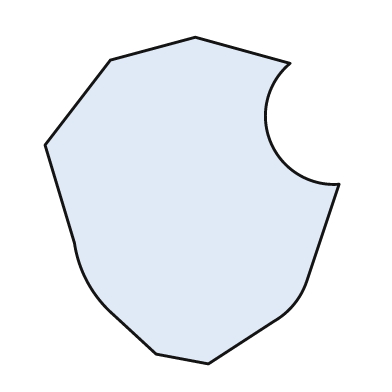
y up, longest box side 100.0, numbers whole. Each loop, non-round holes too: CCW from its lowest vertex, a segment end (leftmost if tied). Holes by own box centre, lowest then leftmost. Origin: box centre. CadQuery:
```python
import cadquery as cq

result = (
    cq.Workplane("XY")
    .moveTo(5.0, -50.0)
    .lineTo(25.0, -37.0)
    .threePointArc((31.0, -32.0), (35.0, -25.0))
    .lineTo(45.0, 5.0)
    .threePointArc((24.0, 18.0), (30.0, 42.0))
    .lineTo(1.0, 50.0)
    .lineTo(-25.0, 43.0)
    .lineTo(-45.0, 17.0)
    .lineTo(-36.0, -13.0)
    .threePointArc((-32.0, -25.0), (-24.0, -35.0))
    .lineTo(-11.0, -47.0)
    .close()
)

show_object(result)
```